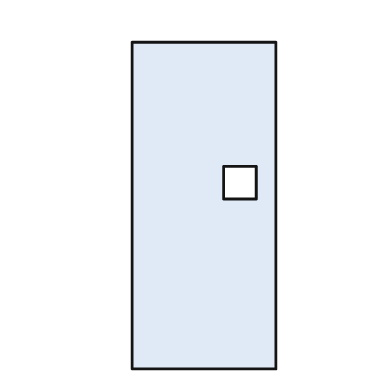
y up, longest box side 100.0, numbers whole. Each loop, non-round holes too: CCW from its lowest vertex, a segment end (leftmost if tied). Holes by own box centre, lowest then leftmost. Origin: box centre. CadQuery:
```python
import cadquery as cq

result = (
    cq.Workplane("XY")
    .moveTo(-22.0, -50.0)
    .lineTo(22.0, -50.0)
    .lineTo(22.0, 50.0)
    .lineTo(-22.0, 50.0)
    .close()
    .moveTo(6.0, 2.0)
    .lineTo(16.0, 2.0)
    .lineTo(16.0, 12.0)
    .lineTo(6.0, 12.0)
    .close()
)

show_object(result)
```